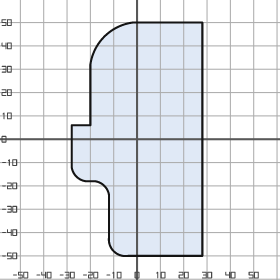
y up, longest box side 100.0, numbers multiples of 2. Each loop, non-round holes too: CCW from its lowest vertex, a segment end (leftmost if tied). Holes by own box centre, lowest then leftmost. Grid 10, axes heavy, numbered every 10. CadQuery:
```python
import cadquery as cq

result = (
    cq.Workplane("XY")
    .moveTo(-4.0, -50.0)
    .lineTo(28.0, -50.0)
    .lineTo(28.0, 50.0)
    .lineTo(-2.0, 50.0)
    .threePointArc((-14.0, 44.0), (-20.0, 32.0))
    .lineTo(-20.0, 6.0)
    .lineTo(-28.0, 6.0)
    .lineTo(-28.0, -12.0)
    .threePointArc((-26.0, -16.0), (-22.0, -18.0))
    .lineTo(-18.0, -18.0)
    .threePointArc((-14.0, -20.0), (-12.0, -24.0))
    .lineTo(-12.0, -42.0)
    .threePointArc((-10.0, -48.0), (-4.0, -50.0))
    .close()
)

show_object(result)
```